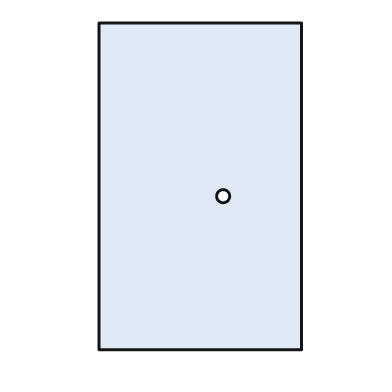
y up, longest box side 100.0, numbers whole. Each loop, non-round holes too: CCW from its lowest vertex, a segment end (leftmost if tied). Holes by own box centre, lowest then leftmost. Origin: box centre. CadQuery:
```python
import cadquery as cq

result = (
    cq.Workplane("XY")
    .moveTo(-31.0, -50.0)
    .lineTo(31.0, -50.0)
    .lineTo(31.0, 50.0)
    .lineTo(-31.0, 50.0)
    .close()
    .moveTo(7.0, -3.0)
    .circle(2.0)
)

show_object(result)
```